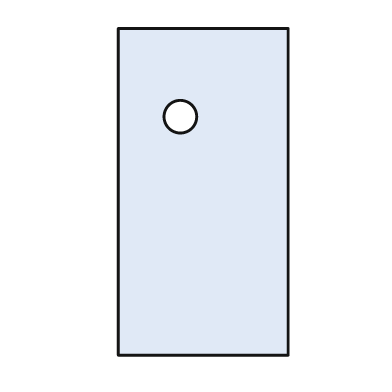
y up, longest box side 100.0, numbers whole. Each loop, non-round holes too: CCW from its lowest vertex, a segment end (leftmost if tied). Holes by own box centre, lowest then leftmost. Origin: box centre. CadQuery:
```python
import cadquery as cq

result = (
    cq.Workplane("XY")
    .moveTo(-26.0, -50.0)
    .lineTo(26.0, -50.0)
    .lineTo(26.0, 50.0)
    .lineTo(-26.0, 50.0)
    .close()
    .moveTo(-7.0, 23.0)
    .circle(5.0)
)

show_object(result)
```